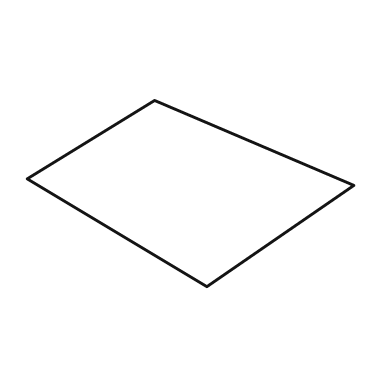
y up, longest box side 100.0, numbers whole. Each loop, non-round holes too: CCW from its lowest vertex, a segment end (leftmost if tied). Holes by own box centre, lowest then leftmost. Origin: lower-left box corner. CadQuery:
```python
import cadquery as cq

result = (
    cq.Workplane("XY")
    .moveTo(55.0, 0.0)
    .lineTo(100.0, 31.0)
    .lineTo(39.0, 57.0)
    .lineTo(0.0, 33.0)
    .close()
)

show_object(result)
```